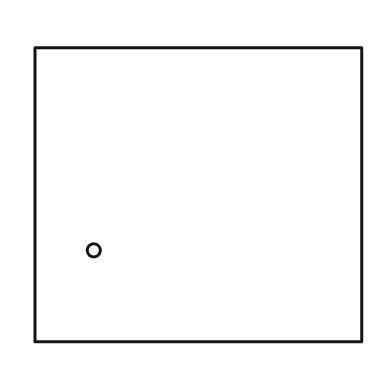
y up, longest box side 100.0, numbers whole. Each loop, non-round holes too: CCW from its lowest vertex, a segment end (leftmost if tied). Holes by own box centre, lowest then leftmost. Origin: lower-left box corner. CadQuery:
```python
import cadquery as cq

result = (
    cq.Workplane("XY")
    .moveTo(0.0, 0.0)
    .lineTo(100.0, 0.0)
    .lineTo(100.0, 90.0)
    .lineTo(0.0, 90.0)
    .close()
    .moveTo(18.0, 28.0)
    .circle(2.0)
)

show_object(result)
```